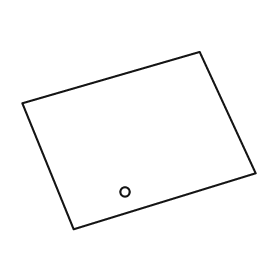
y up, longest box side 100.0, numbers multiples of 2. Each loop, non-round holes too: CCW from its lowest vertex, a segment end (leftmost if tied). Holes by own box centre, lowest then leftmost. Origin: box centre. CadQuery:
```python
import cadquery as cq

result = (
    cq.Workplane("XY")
    .moveTo(-28.0, -38.0)
    .lineTo(50.0, -14.0)
    .lineTo(26.0, 38.0)
    .lineTo(-50.0, 16.0)
    .close()
    .moveTo(-6.0, -22.0)
    .circle(2.0)
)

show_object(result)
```